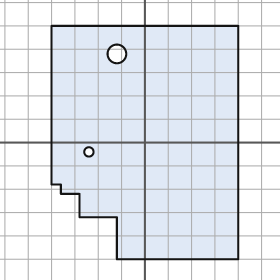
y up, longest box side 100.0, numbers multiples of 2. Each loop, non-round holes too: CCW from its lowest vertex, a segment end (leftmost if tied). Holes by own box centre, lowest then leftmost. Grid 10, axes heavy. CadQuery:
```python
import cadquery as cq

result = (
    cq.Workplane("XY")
    .moveTo(-12.0, -50.0)
    .lineTo(40.0, -50.0)
    .lineTo(40.0, 50.0)
    .lineTo(-40.0, 50.0)
    .lineTo(-40.0, -18.0)
    .lineTo(-36.0, -18.0)
    .lineTo(-36.0, -22.0)
    .lineTo(-28.0, -22.0)
    .lineTo(-28.0, -32.0)
    .lineTo(-12.0, -32.0)
    .close()
    .moveTo(-24.0, -4.0)
    .circle(2.0)
    .moveTo(-12.0, 38.0)
    .circle(4.0)
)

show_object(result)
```